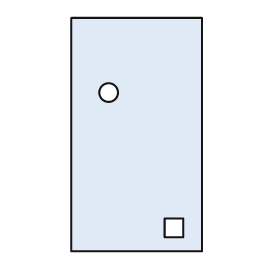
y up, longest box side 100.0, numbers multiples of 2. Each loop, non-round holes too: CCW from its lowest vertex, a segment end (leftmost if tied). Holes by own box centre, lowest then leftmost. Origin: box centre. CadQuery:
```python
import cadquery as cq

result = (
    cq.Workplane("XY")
    .moveTo(-28.0, -50.0)
    .lineTo(28.0, -50.0)
    .lineTo(28.0, 50.0)
    .lineTo(-28.0, 50.0)
    .close()
    .moveTo(12.0, -44.0)
    .lineTo(20.0, -44.0)
    .lineTo(20.0, -36.0)
    .lineTo(12.0, -36.0)
    .close()
    .moveTo(-12.0, 18.0)
    .circle(4.0)
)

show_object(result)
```